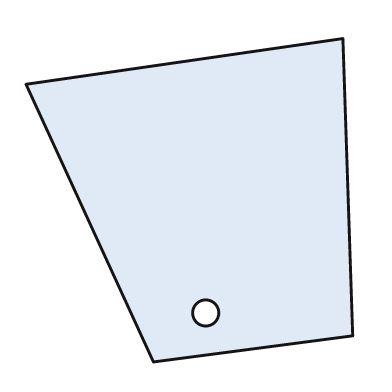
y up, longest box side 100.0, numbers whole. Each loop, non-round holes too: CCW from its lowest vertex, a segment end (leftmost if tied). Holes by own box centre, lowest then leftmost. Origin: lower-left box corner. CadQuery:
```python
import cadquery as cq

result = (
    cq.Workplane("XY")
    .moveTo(39.0, 0.0)
    .lineTo(100.0, 8.0)
    .lineTo(97.0, 99.0)
    .lineTo(0.0, 85.0)
    .close()
    .moveTo(55.0, 15.0)
    .circle(4.0)
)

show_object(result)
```